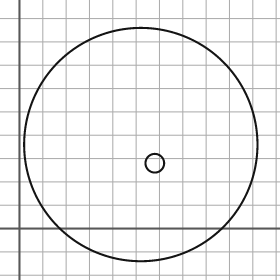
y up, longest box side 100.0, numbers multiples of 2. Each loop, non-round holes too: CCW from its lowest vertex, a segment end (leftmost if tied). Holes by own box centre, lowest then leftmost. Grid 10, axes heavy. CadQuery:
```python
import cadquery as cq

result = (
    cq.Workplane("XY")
    .moveTo(52.0, 36.0)
    .circle(50.0)
    .moveTo(58.0, 28.0)
    .circle(4.0)
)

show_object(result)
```